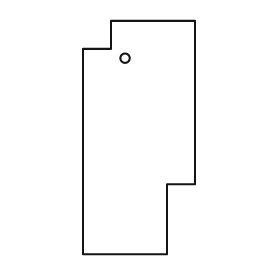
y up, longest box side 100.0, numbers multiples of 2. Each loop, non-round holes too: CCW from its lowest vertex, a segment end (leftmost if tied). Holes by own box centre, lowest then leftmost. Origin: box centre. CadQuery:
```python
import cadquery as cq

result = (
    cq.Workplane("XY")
    .moveTo(-24.0, -50.0)
    .lineTo(12.0, -50.0)
    .lineTo(12.0, -20.0)
    .lineTo(24.0, -20.0)
    .lineTo(24.0, 50.0)
    .lineTo(-12.0, 50.0)
    .lineTo(-12.0, 38.0)
    .lineTo(-24.0, 38.0)
    .close()
    .moveTo(-6.0, 34.0)
    .circle(2.0)
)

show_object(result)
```